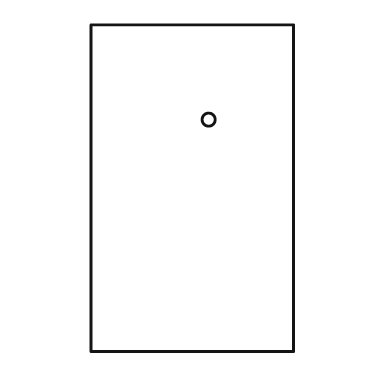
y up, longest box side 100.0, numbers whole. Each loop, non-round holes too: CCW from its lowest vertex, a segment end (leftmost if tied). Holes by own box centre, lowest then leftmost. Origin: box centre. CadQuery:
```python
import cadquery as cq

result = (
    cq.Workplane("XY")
    .moveTo(-31.0, -50.0)
    .lineTo(31.0, -50.0)
    .lineTo(31.0, 50.0)
    .lineTo(-31.0, 50.0)
    .close()
    .moveTo(5.0, 21.0)
    .circle(2.0)
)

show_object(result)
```